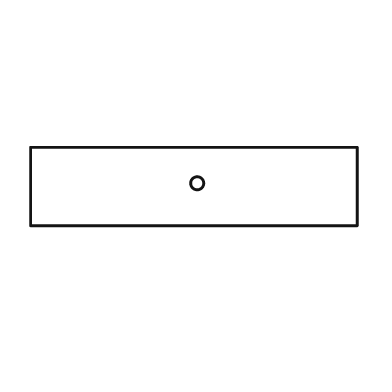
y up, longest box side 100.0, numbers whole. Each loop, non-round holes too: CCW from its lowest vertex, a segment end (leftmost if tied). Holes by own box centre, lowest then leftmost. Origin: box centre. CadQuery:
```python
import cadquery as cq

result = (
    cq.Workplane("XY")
    .moveTo(-50.0, -12.0)
    .lineTo(50.0, -12.0)
    .lineTo(50.0, 12.0)
    .lineTo(-50.0, 12.0)
    .close()
    .moveTo(1.0, 1.0)
    .circle(2.0)
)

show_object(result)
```